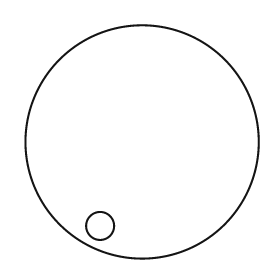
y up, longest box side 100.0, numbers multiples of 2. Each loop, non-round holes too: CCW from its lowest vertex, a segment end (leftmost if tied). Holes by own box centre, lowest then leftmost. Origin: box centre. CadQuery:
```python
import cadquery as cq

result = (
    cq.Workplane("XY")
    .moveTo(0.0, 0.0)
    .circle(50.0)
    .moveTo(-18.0, -36.0)
    .circle(6.0)
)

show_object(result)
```